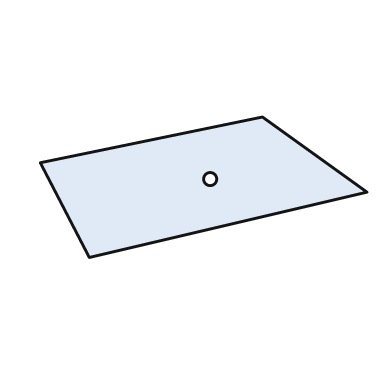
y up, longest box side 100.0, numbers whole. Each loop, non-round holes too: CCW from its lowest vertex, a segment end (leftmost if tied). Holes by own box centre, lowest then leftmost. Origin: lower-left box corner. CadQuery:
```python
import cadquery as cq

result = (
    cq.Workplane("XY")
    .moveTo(15.0, 0.0)
    .lineTo(100.0, 20.0)
    .lineTo(68.0, 43.0)
    .lineTo(0.0, 29.0)
    .close()
    .moveTo(52.0, 24.0)
    .circle(2.0)
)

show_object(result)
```